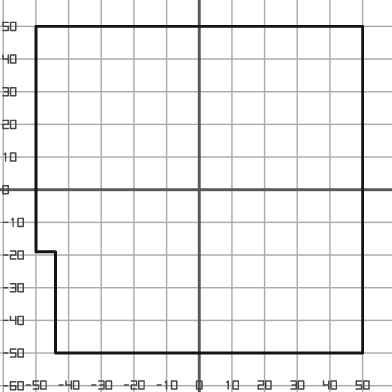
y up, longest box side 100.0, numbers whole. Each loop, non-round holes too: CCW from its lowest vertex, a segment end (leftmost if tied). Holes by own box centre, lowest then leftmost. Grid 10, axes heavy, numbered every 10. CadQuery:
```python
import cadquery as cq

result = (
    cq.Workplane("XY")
    .moveTo(-44.0, -50.0)
    .lineTo(50.0, -50.0)
    .lineTo(50.0, 50.0)
    .lineTo(-50.0, 50.0)
    .lineTo(-50.0, -19.0)
    .lineTo(-44.0, -19.0)
    .close()
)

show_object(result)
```